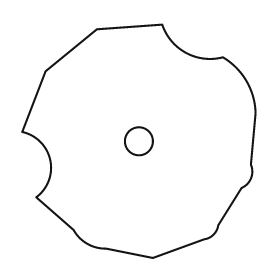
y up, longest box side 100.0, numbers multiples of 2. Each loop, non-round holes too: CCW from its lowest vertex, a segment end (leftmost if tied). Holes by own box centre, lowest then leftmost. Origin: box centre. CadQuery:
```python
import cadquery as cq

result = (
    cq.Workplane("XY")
    .moveTo(6.0, -50.0)
    .lineTo(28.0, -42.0)
    .threePointArc((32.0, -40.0), (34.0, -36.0))
    .lineTo(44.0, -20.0)
    .threePointArc((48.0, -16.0), (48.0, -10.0))
    .lineTo(50.0, 12.0)
    .threePointArc((46.0, 26.0), (36.0, 36.0))
    .threePointArc((20.0, 38.0), (10.0, 50.0))
    .lineTo(-18.0, 48.0)
    .lineTo(-40.0, 30.0)
    .lineTo(-50.0, 4.0)
    .threePointArc((-38.0, -8.0), (-44.0, -24.0))
    .lineTo(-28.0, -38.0)
    .threePointArc((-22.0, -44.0), (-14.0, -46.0))
    .close()
    .moveTo(0.0, 0.0)
    .circle(6.0)
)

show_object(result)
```